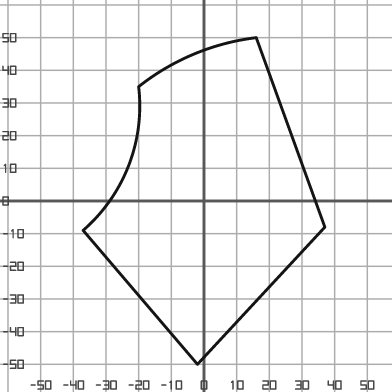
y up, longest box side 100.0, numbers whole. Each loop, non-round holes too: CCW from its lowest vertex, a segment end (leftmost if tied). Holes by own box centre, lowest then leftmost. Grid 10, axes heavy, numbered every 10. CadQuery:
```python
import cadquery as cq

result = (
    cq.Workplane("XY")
    .moveTo(-2.0, -50.0)
    .lineTo(37.0, -8.0)
    .lineTo(16.0, 50.0)
    .threePointArc((-3.0, 45.0), (-20.0, 35.0))
    .threePointArc((-23.0, 11.0), (-37.0, -9.0))
    .close()
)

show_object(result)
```